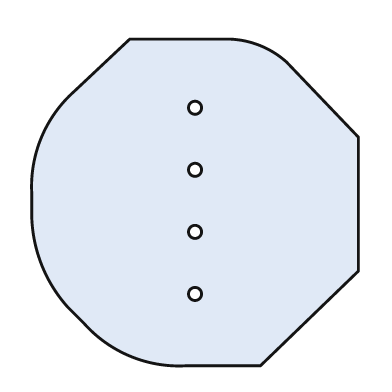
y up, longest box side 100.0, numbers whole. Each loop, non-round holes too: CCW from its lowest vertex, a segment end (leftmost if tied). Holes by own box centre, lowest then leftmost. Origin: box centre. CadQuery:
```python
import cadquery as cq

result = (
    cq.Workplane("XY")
    .moveTo(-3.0, -50.0)
    .lineTo(20.0, -50.0)
    .lineTo(50.0, -21.0)
    .lineTo(50.0, 20.0)
    .lineTo(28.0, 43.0)
    .threePointArc((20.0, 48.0), (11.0, 50.0))
    .lineTo(-20.0, 50.0)
    .lineTo(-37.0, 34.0)
    .threePointArc((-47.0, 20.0), (-50.0, 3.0))
    .lineTo(-50.0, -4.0)
    .threePointArc((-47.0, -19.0), (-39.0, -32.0))
    .lineTo(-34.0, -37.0)
    .threePointArc((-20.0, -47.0), (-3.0, -50.0))
    .close()
    .moveTo(0.0, -28.0)
    .circle(2.0)
    .moveTo(0.0, -9.0)
    .circle(2.0)
    .moveTo(0.0, 10.0)
    .circle(2.0)
    .moveTo(0.0, 29.0)
    .circle(2.0)
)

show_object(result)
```